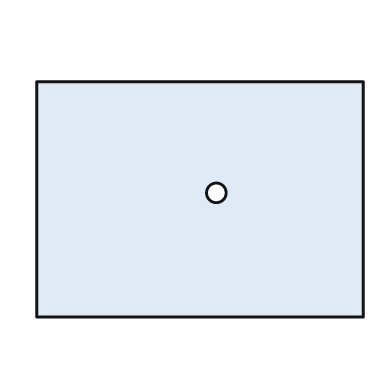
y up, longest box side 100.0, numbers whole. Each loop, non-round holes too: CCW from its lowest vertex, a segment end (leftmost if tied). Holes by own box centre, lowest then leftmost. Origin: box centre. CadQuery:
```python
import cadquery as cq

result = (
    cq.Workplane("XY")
    .moveTo(-50.0, -36.0)
    .lineTo(50.0, -36.0)
    .lineTo(50.0, 36.0)
    .lineTo(-50.0, 36.0)
    .close()
    .moveTo(5.0, 2.0)
    .circle(3.0)
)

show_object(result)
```